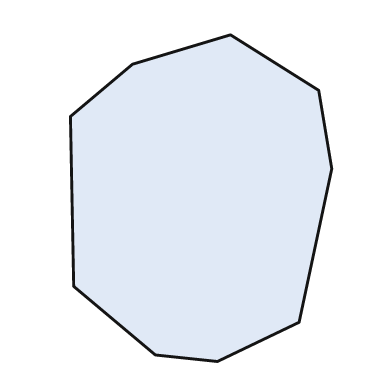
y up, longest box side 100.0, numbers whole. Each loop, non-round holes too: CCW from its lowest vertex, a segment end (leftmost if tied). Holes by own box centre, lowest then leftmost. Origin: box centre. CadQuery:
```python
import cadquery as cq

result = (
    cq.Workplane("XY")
    .moveTo(5.0, -50.0)
    .lineTo(30.0, -38.0)
    .lineTo(40.0, 9.0)
    .lineTo(36.0, 33.0)
    .lineTo(9.0, 50.0)
    .lineTo(-21.0, 41.0)
    .lineTo(-40.0, 25.0)
    .lineTo(-39.0, -27.0)
    .lineTo(-14.0, -48.0)
    .close()
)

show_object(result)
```